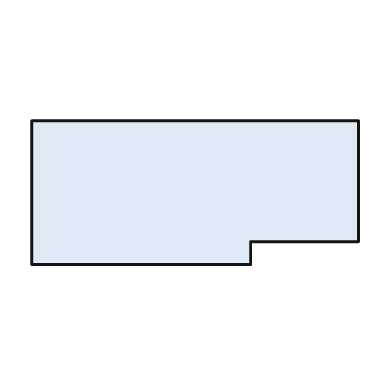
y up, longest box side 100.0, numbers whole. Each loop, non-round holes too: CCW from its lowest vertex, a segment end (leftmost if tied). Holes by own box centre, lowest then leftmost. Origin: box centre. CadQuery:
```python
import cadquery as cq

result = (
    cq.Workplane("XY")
    .moveTo(-50.0, -22.0)
    .lineTo(17.0, -22.0)
    .lineTo(17.0, -15.0)
    .lineTo(50.0, -15.0)
    .lineTo(50.0, 22.0)
    .lineTo(-50.0, 22.0)
    .close()
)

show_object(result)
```